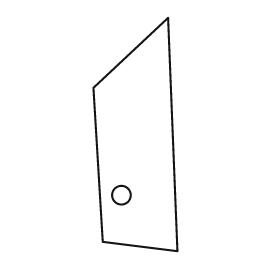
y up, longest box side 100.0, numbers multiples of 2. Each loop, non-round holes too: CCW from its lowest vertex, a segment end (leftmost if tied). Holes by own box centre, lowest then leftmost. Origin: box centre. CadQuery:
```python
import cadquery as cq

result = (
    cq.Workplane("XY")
    .moveTo(18.0, -50.0)
    .lineTo(14.0, 50.0)
    .lineTo(-18.0, 20.0)
    .lineTo(-14.0, -46.0)
    .close()
    .moveTo(-6.0, -26.0)
    .circle(4.0)
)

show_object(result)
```